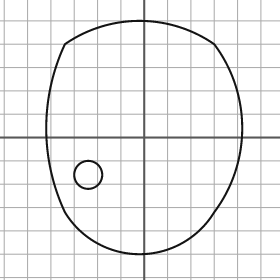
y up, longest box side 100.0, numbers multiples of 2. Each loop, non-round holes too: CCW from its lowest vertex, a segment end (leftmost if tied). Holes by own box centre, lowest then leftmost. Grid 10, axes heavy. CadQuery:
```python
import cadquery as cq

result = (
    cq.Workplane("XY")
    .moveTo(-34.0, -32.0)
    .threePointArc((-2.0, -50.0), (30.0, -32.0))
    .threePointArc((42.0, 4.0), (30.0, 40.0))
    .threePointArc((-2.0, 50.0), (-34.0, 40.0))
    .threePointArc((-42.0, 4.0), (-34.0, -32.0))
    .close()
    .moveTo(-24.0, -16.0)
    .circle(6.0)
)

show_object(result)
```